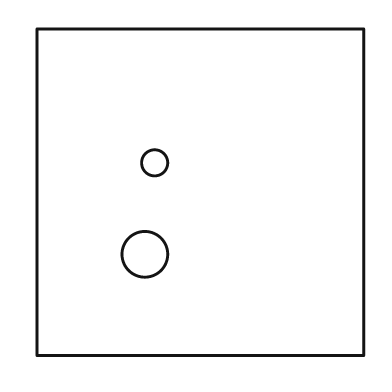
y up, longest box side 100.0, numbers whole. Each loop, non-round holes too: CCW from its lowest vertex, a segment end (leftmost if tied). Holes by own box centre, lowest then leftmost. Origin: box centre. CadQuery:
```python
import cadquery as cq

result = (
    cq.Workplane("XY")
    .moveTo(-50.0, -50.0)
    .lineTo(50.0, -50.0)
    .lineTo(50.0, 50.0)
    .lineTo(-50.0, 50.0)
    .close()
    .moveTo(-17.0, -19.0)
    .circle(7.0)
    .moveTo(-14.0, 9.0)
    .circle(4.0)
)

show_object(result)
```